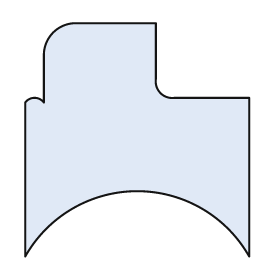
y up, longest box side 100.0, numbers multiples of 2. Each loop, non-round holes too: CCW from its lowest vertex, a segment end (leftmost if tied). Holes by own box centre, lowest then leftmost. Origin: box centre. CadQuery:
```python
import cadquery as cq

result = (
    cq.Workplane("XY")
    .moveTo(-48.0, -50.0)
    .threePointArc((0.0, -22.0), (48.0, -50.0))
    .lineTo(48.0, 18.0)
    .lineTo(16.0, 18.0)
    .threePointArc((10.0, 20.0), (8.0, 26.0))
    .lineTo(8.0, 50.0)
    .lineTo(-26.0, 50.0)
    .threePointArc((-36.0, 46.0), (-40.0, 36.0))
    .lineTo(-40.0, 16.0)
    .threePointArc((-44.0, 18.0), (-48.0, 16.0))
    .close()
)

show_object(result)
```